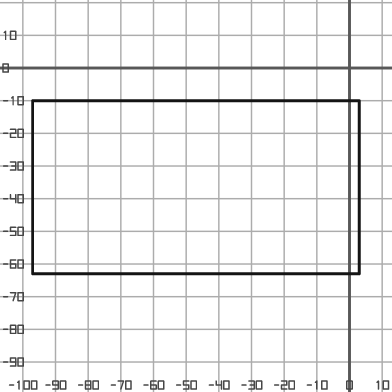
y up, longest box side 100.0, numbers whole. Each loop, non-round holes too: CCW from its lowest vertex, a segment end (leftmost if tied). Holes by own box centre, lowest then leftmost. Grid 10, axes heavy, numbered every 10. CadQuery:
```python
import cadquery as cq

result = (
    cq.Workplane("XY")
    .moveTo(-97.0, -63.0)
    .lineTo(3.0, -63.0)
    .lineTo(3.0, -10.0)
    .lineTo(-97.0, -10.0)
    .close()
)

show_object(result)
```